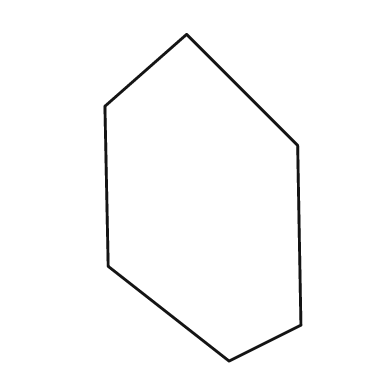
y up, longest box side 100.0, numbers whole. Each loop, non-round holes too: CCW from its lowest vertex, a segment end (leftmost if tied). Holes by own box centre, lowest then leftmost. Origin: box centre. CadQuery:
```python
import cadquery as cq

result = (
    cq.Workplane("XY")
    .moveTo(8.0, -50.0)
    .lineTo(30.0, -39.0)
    .lineTo(29.0, 16.0)
    .lineTo(-5.0, 50.0)
    .lineTo(-30.0, 28.0)
    .lineTo(-29.0, -21.0)
    .close()
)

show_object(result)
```